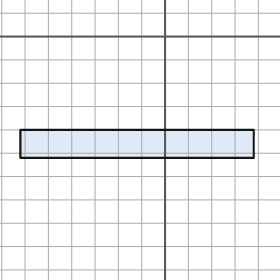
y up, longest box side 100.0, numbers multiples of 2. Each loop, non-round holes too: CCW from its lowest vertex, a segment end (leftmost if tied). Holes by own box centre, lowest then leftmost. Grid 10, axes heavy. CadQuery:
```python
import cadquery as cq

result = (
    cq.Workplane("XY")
    .moveTo(-62.0, -52.0)
    .lineTo(38.0, -52.0)
    .lineTo(38.0, -40.0)
    .lineTo(-62.0, -40.0)
    .close()
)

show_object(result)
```